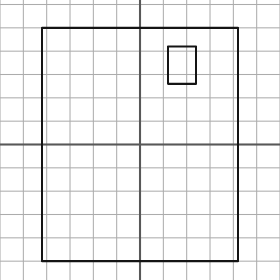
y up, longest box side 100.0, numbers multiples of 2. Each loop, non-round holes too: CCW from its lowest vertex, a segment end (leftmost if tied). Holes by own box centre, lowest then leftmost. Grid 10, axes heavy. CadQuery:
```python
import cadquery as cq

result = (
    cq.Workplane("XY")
    .moveTo(-42.0, -50.0)
    .lineTo(42.0, -50.0)
    .lineTo(42.0, 50.0)
    .lineTo(-42.0, 50.0)
    .close()
    .moveTo(12.0, 26.0)
    .lineTo(24.0, 26.0)
    .lineTo(24.0, 42.0)
    .lineTo(12.0, 42.0)
    .close()
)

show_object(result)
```